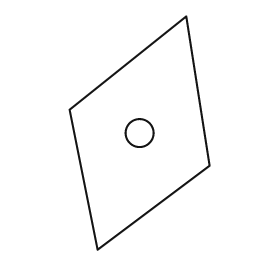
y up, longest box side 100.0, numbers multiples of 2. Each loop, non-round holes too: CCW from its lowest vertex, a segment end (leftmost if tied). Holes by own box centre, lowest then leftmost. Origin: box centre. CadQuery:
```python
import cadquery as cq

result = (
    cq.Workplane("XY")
    .moveTo(-18.0, -50.0)
    .lineTo(30.0, -14.0)
    .lineTo(20.0, 50.0)
    .lineTo(-30.0, 10.0)
    .close()
    .moveTo(0.0, 0.0)
    .circle(6.0)
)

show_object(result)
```